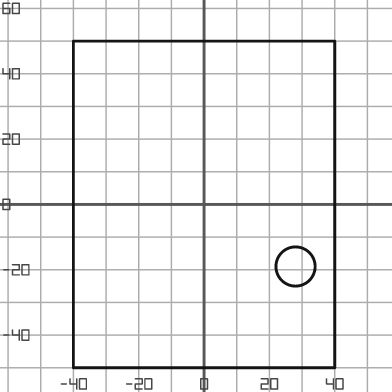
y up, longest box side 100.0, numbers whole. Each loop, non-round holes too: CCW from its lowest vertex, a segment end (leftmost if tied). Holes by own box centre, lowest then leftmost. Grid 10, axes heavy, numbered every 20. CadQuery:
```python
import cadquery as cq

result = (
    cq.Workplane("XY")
    .moveTo(-40.0, -50.0)
    .lineTo(40.0, -50.0)
    .lineTo(40.0, 50.0)
    .lineTo(-40.0, 50.0)
    .close()
    .moveTo(28.0, -19.0)
    .circle(6.0)
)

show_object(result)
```